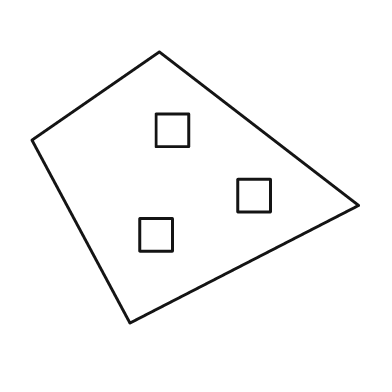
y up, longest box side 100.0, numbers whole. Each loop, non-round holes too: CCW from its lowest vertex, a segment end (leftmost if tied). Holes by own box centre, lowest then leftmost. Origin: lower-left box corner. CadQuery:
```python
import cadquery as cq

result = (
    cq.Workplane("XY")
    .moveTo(30.0, 0.0)
    .lineTo(100.0, 36.0)
    .lineTo(39.0, 83.0)
    .lineTo(0.0, 56.0)
    .close()
    .moveTo(33.0, 22.0)
    .lineTo(43.0, 22.0)
    .lineTo(43.0, 32.0)
    .lineTo(33.0, 32.0)
    .close()
    .moveTo(63.0, 34.0)
    .lineTo(73.0, 34.0)
    .lineTo(73.0, 44.0)
    .lineTo(63.0, 44.0)
    .close()
    .moveTo(38.0, 54.0)
    .lineTo(48.0, 54.0)
    .lineTo(48.0, 64.0)
    .lineTo(38.0, 64.0)
    .close()
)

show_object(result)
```